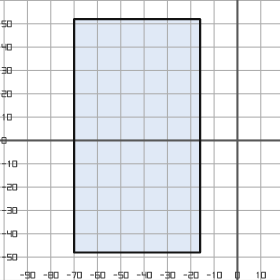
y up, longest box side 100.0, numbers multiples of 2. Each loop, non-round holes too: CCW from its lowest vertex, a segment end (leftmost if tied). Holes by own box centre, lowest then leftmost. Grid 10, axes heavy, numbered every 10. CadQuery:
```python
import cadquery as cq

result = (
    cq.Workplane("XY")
    .moveTo(-70.0, -48.0)
    .lineTo(-16.0, -48.0)
    .lineTo(-16.0, 52.0)
    .lineTo(-70.0, 52.0)
    .close()
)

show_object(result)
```